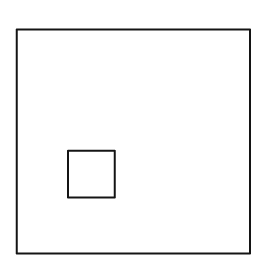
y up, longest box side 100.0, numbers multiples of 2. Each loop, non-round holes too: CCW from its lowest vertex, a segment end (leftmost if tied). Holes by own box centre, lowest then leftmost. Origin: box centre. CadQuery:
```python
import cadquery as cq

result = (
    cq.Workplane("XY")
    .moveTo(-50.0, -48.0)
    .lineTo(50.0, -48.0)
    .lineTo(50.0, 48.0)
    .lineTo(-50.0, 48.0)
    .close()
    .moveTo(-28.0, -24.0)
    .lineTo(-8.0, -24.0)
    .lineTo(-8.0, -4.0)
    .lineTo(-28.0, -4.0)
    .close()
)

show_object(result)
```